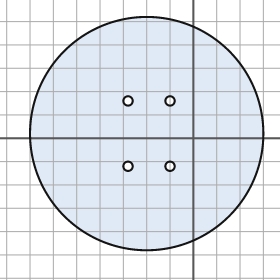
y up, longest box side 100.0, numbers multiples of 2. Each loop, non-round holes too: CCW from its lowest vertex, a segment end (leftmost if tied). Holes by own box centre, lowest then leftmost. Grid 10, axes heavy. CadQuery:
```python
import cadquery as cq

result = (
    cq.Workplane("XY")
    .moveTo(-20.0, 2.0)
    .circle(50.0)
    .moveTo(-28.0, -12.0)
    .circle(2.0)
    .moveTo(-10.0, -12.0)
    .circle(2.0)
    .moveTo(-28.0, 16.0)
    .circle(2.0)
    .moveTo(-10.0, 16.0)
    .circle(2.0)
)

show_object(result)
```